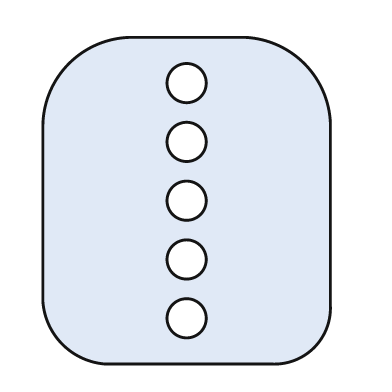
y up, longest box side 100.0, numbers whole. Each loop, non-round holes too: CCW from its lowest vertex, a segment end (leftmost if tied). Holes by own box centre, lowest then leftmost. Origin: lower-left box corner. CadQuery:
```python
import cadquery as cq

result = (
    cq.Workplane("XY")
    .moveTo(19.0, 0.0)
    .lineTo(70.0, 0.0)
    .threePointArc((83.0, 5.0), (88.0, 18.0))
    .lineTo(88.0, 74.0)
    .threePointArc((80.0, 92.0), (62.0, 100.0))
    .lineTo(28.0, 100.0)
    .threePointArc((8.0, 92.0), (0.0, 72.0))
    .lineTo(0.0, 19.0)
    .threePointArc((6.0, 6.0), (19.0, 0.0))
    .close()
    .moveTo(44.0, 14.0)
    .circle(6.0)
    .moveTo(44.0, 32.0)
    .circle(6.0)
    .moveTo(44.0, 50.0)
    .circle(6.0)
    .moveTo(44.0, 68.0)
    .circle(6.0)
    .moveTo(44.0, 86.0)
    .circle(6.0)
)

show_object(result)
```